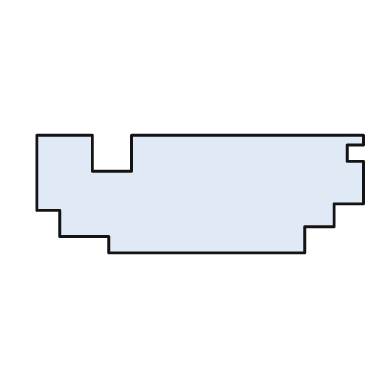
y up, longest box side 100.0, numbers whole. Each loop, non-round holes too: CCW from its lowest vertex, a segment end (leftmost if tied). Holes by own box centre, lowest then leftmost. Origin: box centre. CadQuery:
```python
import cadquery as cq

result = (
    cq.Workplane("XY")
    .moveTo(-28.0, -18.0)
    .lineTo(32.0, -18.0)
    .lineTo(32.0, -10.0)
    .lineTo(41.0, -10.0)
    .lineTo(41.0, -3.0)
    .lineTo(50.0, -3.0)
    .lineTo(50.0, 10.0)
    .lineTo(45.0, 10.0)
    .lineTo(45.0, 15.0)
    .lineTo(50.0, 15.0)
    .lineTo(50.0, 18.0)
    .lineTo(-21.0, 18.0)
    .lineTo(-21.0, 7.0)
    .lineTo(-33.0, 7.0)
    .lineTo(-33.0, 18.0)
    .lineTo(-50.0, 18.0)
    .lineTo(-50.0, -5.0)
    .lineTo(-43.0, -5.0)
    .lineTo(-43.0, -13.0)
    .lineTo(-28.0, -13.0)
    .close()
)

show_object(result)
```